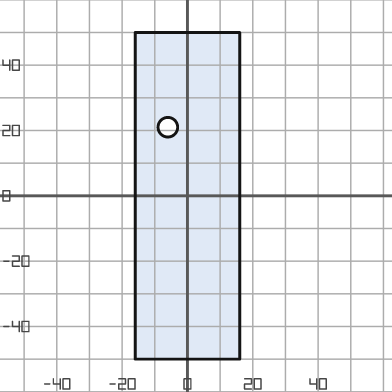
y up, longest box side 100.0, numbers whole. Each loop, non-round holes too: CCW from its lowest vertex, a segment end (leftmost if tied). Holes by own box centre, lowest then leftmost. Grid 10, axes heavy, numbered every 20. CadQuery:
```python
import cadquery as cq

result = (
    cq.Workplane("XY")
    .moveTo(-16.0, -50.0)
    .lineTo(16.0, -50.0)
    .lineTo(16.0, 50.0)
    .lineTo(-16.0, 50.0)
    .close()
    .moveTo(-6.0, 21.0)
    .circle(3.0)
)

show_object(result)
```